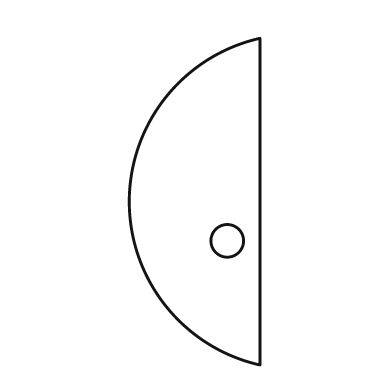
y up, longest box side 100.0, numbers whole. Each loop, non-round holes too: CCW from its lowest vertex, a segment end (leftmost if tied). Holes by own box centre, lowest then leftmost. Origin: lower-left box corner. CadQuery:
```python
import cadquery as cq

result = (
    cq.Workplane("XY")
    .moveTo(40.0, 0.0)
    .lineTo(40.0, 100.0)
    .threePointArc((0.0, 50.0), (40.0, 0.0))
    .close()
    .moveTo(30.0, 38.0)
    .circle(5.0)
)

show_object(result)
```